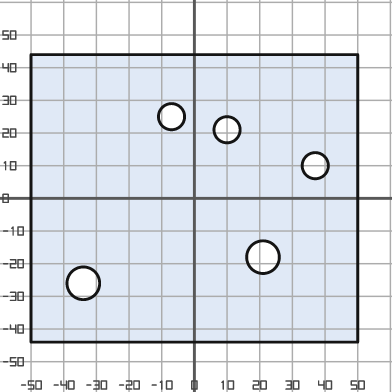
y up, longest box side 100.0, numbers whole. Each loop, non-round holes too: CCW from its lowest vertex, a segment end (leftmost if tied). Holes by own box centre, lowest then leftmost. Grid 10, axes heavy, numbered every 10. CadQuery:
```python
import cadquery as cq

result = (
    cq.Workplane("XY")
    .moveTo(-50.0, -44.0)
    .lineTo(50.0, -44.0)
    .lineTo(50.0, 44.0)
    .lineTo(-50.0, 44.0)
    .close()
    .moveTo(-34.0, -26.0)
    .circle(5.0)
    .moveTo(21.0, -18.0)
    .circle(5.0)
    .moveTo(37.0, 10.0)
    .circle(4.0)
    .moveTo(10.0, 21.0)
    .circle(4.0)
    .moveTo(-7.0, 25.0)
    .circle(4.0)
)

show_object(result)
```